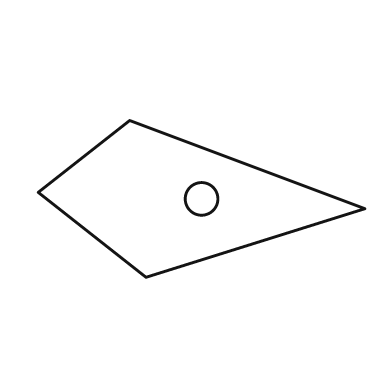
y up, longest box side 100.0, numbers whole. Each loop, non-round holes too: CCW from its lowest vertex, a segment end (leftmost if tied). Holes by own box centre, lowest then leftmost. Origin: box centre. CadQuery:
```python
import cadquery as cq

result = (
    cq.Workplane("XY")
    .moveTo(-17.0, -24.0)
    .lineTo(50.0, -3.0)
    .lineTo(-22.0, 24.0)
    .lineTo(-50.0, 2.0)
    .close()
    .moveTo(0.0, 0.0)
    .circle(5.0)
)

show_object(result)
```